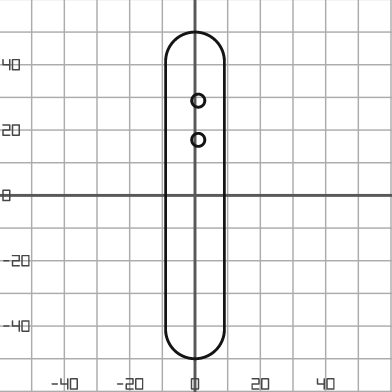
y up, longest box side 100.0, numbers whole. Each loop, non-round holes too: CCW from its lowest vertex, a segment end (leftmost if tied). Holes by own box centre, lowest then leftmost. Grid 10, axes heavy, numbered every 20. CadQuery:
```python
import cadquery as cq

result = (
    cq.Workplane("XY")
    .moveTo(-9.0, -41.0)
    .threePointArc((0.0, -50.0), (9.0, -41.0))
    .lineTo(9.0, 41.0)
    .threePointArc((0.0, 50.0), (-9.0, 41.0))
    .close()
    .moveTo(1.0, 17.0)
    .circle(2.0)
    .moveTo(1.0, 29.0)
    .circle(2.0)
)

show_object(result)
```